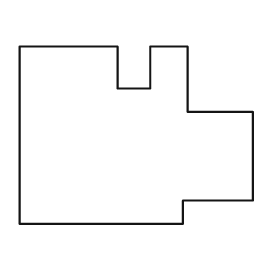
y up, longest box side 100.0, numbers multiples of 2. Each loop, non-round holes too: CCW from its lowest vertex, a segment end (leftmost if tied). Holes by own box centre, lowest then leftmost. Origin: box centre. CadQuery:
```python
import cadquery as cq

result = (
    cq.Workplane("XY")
    .moveTo(-50.0, -38.0)
    .lineTo(20.0, -38.0)
    .lineTo(20.0, -28.0)
    .lineTo(50.0, -28.0)
    .lineTo(50.0, 10.0)
    .lineTo(22.0, 10.0)
    .lineTo(22.0, 38.0)
    .lineTo(6.0, 38.0)
    .lineTo(6.0, 20.0)
    .lineTo(-8.0, 20.0)
    .lineTo(-8.0, 38.0)
    .lineTo(-50.0, 38.0)
    .close()
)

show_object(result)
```